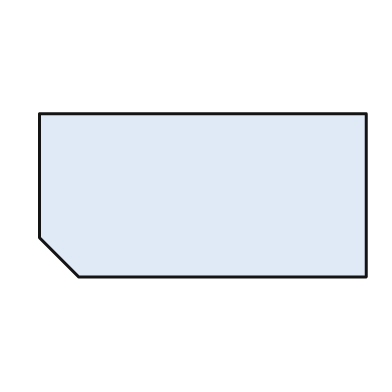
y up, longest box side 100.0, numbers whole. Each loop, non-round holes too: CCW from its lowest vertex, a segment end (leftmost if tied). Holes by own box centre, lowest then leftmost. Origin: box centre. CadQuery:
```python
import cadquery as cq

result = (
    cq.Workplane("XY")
    .moveTo(-38.0, -25.0)
    .lineTo(50.0, -25.0)
    .lineTo(50.0, 25.0)
    .lineTo(-50.0, 25.0)
    .lineTo(-50.0, -13.0)
    .close()
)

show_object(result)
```